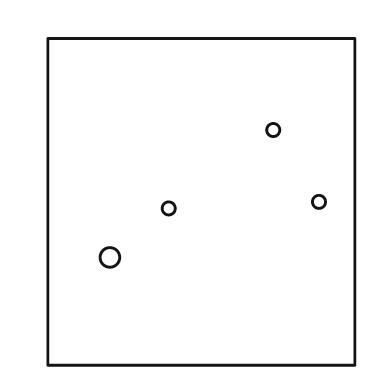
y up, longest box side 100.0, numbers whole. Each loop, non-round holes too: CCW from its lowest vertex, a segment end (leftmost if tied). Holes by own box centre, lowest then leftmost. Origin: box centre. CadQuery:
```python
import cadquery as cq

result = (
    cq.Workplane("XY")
    .moveTo(-47.0, -50.0)
    .lineTo(47.0, -50.0)
    .lineTo(47.0, 50.0)
    .lineTo(-47.0, 50.0)
    .close()
    .moveTo(-28.0, -17.0)
    .circle(3.0)
    .moveTo(-10.0, -2.0)
    .circle(2.0)
    .moveTo(36.0, 0.0)
    .circle(2.0)
    .moveTo(22.0, 22.0)
    .circle(2.0)
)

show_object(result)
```